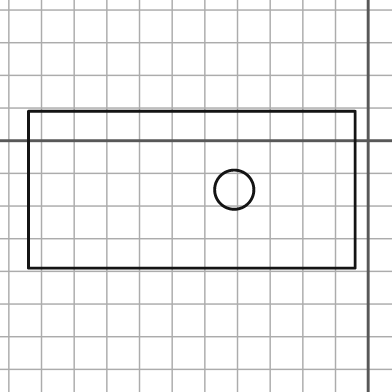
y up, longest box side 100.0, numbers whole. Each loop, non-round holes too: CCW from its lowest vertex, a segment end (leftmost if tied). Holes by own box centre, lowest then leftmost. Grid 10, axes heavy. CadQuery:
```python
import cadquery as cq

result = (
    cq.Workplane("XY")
    .moveTo(-104.0, -39.0)
    .lineTo(-4.0, -39.0)
    .lineTo(-4.0, 9.0)
    .lineTo(-104.0, 9.0)
    .close()
    .moveTo(-41.0, -15.0)
    .circle(6.0)
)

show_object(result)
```